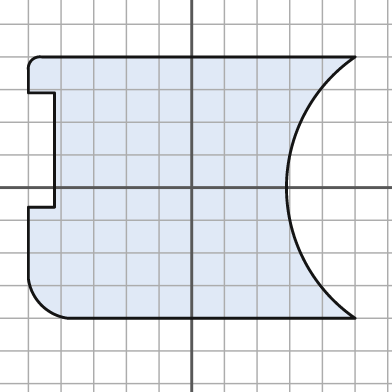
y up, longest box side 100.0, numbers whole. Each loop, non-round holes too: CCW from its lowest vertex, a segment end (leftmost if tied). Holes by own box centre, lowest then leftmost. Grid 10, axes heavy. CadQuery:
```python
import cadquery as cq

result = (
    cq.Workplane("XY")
    .moveTo(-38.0, -40.0)
    .lineTo(50.0, -40.0)
    .threePointArc((29.0, 0.0), (50.0, 40.0))
    .lineTo(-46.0, 40.0)
    .threePointArc((-49.0, 39.0), (-50.0, 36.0))
    .lineTo(-50.0, 29.0)
    .lineTo(-42.0, 29.0)
    .lineTo(-42.0, -6.0)
    .lineTo(-50.0, -6.0)
    .lineTo(-50.0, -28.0)
    .threePointArc((-46.0, -36.0), (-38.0, -40.0))
    .close()
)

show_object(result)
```